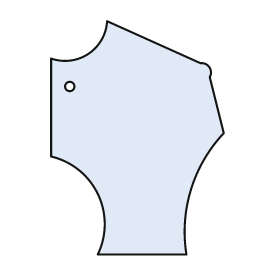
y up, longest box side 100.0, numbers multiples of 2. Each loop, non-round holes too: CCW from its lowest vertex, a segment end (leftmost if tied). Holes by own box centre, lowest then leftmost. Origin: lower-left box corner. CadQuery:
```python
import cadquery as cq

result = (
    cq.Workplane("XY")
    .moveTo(20.0, 0.0)
    .lineTo(58.0, 0.0)
    .threePointArc((60.0, 28.0), (74.0, 52.0))
    .lineTo(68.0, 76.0)
    .threePointArc((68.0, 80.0), (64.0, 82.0))
    .lineTo(24.0, 100.0)
    .threePointArc((16.0, 86.0), (0.0, 84.0))
    .lineTo(0.0, 42.0)
    .threePointArc((20.0, 26.0), (20.0, 0.0))
    .close()
    .moveTo(8.0, 72.0)
    .circle(2.0)
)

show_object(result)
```